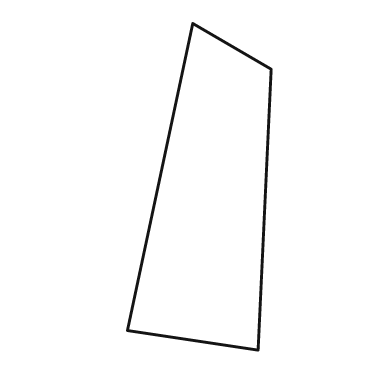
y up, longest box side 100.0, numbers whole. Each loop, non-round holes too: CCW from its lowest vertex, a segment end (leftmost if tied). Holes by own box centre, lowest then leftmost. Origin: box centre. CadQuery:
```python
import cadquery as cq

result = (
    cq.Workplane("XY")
    .moveTo(18.0, -50.0)
    .lineTo(22.0, 36.0)
    .lineTo(-2.0, 50.0)
    .lineTo(-22.0, -44.0)
    .close()
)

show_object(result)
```